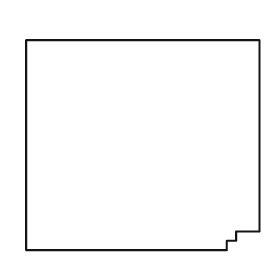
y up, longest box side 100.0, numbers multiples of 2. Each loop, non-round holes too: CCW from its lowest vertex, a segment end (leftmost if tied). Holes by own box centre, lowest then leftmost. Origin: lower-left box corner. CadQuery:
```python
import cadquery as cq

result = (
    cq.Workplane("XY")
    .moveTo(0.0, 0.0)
    .lineTo(86.0, 0.0)
    .lineTo(86.0, 4.0)
    .lineTo(90.0, 4.0)
    .lineTo(90.0, 8.0)
    .lineTo(100.0, 8.0)
    .lineTo(100.0, 90.0)
    .lineTo(0.0, 90.0)
    .close()
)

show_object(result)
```